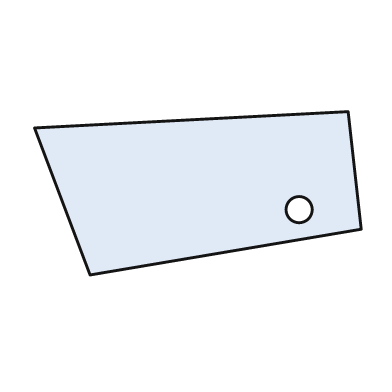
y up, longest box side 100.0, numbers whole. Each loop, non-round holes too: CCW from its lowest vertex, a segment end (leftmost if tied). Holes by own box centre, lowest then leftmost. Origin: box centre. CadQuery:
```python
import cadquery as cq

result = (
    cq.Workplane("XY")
    .moveTo(-33.0, -25.0)
    .lineTo(50.0, -11.0)
    .lineTo(46.0, 25.0)
    .lineTo(-50.0, 20.0)
    .close()
    .moveTo(31.0, -5.0)
    .circle(4.0)
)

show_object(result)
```